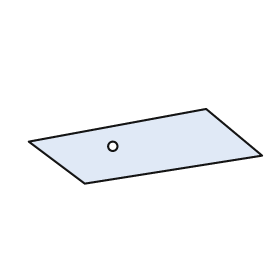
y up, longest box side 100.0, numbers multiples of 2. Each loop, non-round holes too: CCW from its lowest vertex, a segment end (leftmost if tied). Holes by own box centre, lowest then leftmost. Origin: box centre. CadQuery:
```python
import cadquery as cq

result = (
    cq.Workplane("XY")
    .moveTo(-26.0, -16.0)
    .lineTo(50.0, -4.0)
    .lineTo(26.0, 16.0)
    .lineTo(-50.0, 2.0)
    .close()
    .moveTo(-14.0, 0.0)
    .circle(2.0)
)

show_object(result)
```